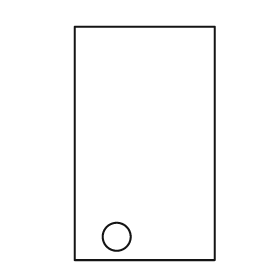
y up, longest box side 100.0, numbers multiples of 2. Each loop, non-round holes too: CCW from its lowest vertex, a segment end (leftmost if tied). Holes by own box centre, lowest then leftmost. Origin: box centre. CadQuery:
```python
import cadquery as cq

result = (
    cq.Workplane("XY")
    .moveTo(-30.0, -50.0)
    .lineTo(30.0, -50.0)
    .lineTo(30.0, 50.0)
    .lineTo(-30.0, 50.0)
    .close()
    .moveTo(-12.0, -40.0)
    .circle(6.0)
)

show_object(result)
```